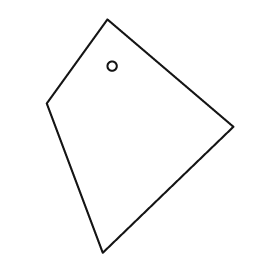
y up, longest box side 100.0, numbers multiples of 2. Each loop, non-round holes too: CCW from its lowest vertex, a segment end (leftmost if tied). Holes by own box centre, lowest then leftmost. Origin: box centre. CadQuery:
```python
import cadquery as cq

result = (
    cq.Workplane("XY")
    .moveTo(-16.0, -50.0)
    .lineTo(40.0, 4.0)
    .lineTo(-14.0, 50.0)
    .lineTo(-40.0, 14.0)
    .close()
    .moveTo(-12.0, 30.0)
    .circle(2.0)
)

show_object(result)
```